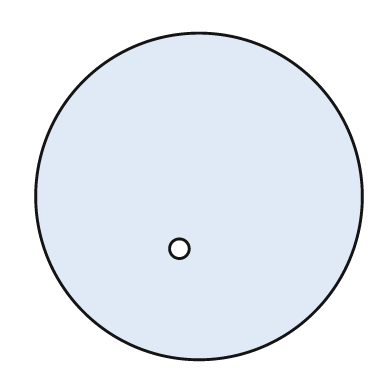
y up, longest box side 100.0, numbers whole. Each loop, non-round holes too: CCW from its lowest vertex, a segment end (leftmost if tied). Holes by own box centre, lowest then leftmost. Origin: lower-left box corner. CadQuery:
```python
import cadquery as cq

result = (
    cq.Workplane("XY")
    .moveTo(50.0, 50.0)
    .circle(50.0)
    .moveTo(44.0, 34.0)
    .circle(3.0)
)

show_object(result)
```